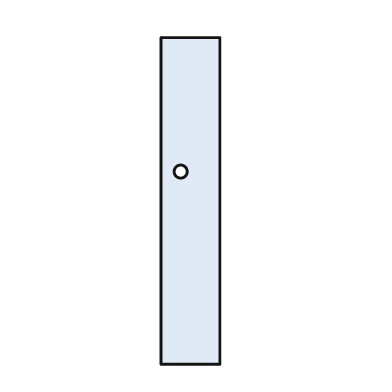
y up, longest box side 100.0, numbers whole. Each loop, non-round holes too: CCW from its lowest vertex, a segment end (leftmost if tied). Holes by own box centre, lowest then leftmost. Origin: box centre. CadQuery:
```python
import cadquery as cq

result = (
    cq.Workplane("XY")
    .moveTo(-9.0, -50.0)
    .lineTo(9.0, -50.0)
    .lineTo(9.0, 50.0)
    .lineTo(-9.0, 50.0)
    .close()
    .moveTo(-3.0, 9.0)
    .circle(2.0)
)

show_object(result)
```